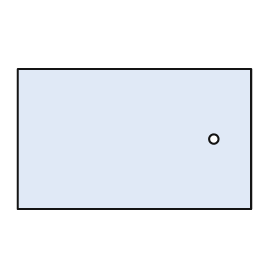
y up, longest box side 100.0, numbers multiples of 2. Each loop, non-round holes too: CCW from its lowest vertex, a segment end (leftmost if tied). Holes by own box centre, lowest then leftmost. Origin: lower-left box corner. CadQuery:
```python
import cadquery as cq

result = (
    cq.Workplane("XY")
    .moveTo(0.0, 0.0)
    .lineTo(100.0, 0.0)
    .lineTo(100.0, 60.0)
    .lineTo(0.0, 60.0)
    .close()
    .moveTo(84.0, 30.0)
    .circle(2.0)
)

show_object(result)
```